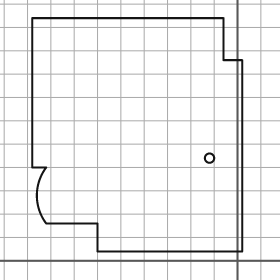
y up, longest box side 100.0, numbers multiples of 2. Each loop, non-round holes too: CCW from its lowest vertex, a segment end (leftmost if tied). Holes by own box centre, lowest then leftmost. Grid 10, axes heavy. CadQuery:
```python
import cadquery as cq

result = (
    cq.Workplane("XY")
    .moveTo(-60.0, 4.0)
    .lineTo(2.0, 4.0)
    .lineTo(2.0, 86.0)
    .lineTo(-6.0, 86.0)
    .lineTo(-6.0, 104.0)
    .lineTo(-88.0, 104.0)
    .lineTo(-88.0, 40.0)
    .lineTo(-82.0, 40.0)
    .threePointArc((-86.0, 28.0), (-82.0, 16.0))
    .lineTo(-60.0, 16.0)
    .close()
    .moveTo(-12.0, 44.0)
    .circle(2.0)
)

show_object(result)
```